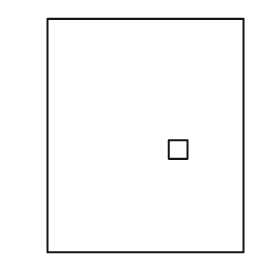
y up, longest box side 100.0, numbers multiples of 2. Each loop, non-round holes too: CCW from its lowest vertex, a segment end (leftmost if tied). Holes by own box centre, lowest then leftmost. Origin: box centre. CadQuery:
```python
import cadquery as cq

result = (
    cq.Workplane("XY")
    .moveTo(-42.0, -50.0)
    .lineTo(42.0, -50.0)
    .lineTo(42.0, 50.0)
    .lineTo(-42.0, 50.0)
    .close()
    .moveTo(10.0, -10.0)
    .lineTo(18.0, -10.0)
    .lineTo(18.0, -2.0)
    .lineTo(10.0, -2.0)
    .close()
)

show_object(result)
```